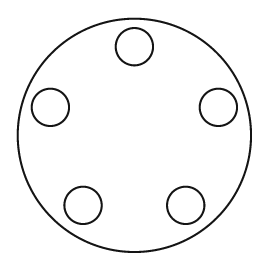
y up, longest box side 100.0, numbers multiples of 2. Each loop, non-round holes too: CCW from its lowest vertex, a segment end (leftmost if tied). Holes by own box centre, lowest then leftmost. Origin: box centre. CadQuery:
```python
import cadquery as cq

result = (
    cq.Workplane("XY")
    .moveTo(0.0, 0.0)
    .circle(50.0)
    .moveTo(-22.0, -30.0)
    .circle(8.0)
    .moveTo(22.0, -30.0)
    .circle(8.0)
    .moveTo(-36.0, 12.0)
    .circle(8.0)
    .moveTo(36.0, 12.0)
    .circle(8.0)
    .moveTo(0.0, 38.0)
    .circle(8.0)
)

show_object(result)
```